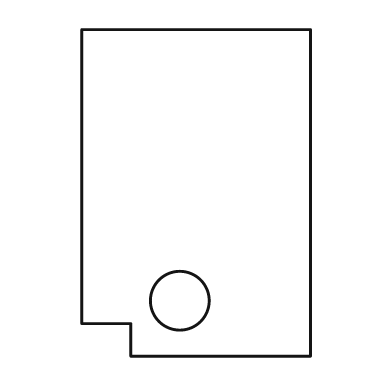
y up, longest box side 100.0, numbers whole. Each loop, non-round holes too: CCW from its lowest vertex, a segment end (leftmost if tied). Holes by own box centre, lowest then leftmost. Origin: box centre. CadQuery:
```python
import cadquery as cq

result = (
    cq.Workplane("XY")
    .moveTo(-20.0, -50.0)
    .lineTo(35.0, -50.0)
    .lineTo(35.0, 50.0)
    .lineTo(-35.0, 50.0)
    .lineTo(-35.0, -40.0)
    .lineTo(-20.0, -40.0)
    .close()
    .moveTo(-5.0, -33.0)
    .circle(9.0)
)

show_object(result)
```